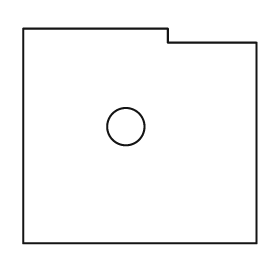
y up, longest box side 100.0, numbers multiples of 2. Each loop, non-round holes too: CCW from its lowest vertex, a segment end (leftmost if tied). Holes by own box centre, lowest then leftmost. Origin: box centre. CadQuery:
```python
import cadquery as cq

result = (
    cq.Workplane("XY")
    .moveTo(-50.0, -46.0)
    .lineTo(50.0, -46.0)
    .lineTo(50.0, 40.0)
    .lineTo(12.0, 40.0)
    .lineTo(12.0, 46.0)
    .lineTo(-50.0, 46.0)
    .close()
    .moveTo(-6.0, 4.0)
    .circle(8.0)
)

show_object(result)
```